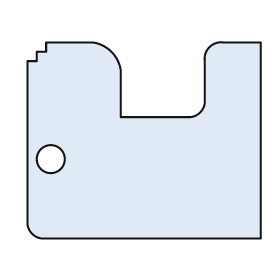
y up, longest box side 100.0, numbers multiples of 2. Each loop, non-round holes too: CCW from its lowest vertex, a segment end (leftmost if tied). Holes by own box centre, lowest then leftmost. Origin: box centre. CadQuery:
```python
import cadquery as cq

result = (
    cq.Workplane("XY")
    .moveTo(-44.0, -42.0)
    .lineTo(50.0, -42.0)
    .lineTo(50.0, 42.0)
    .lineTo(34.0, 42.0)
    .threePointArc((28.0, 40.0), (26.0, 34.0))
    .lineTo(26.0, 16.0)
    .threePointArc((24.0, 12.0), (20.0, 10.0))
    .lineTo(-10.0, 10.0)
    .lineTo(-10.0, 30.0)
    .threePointArc((-14.0, 38.0), (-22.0, 42.0))
    .lineTo(-42.0, 42.0)
    .lineTo(-42.0, 38.0)
    .lineTo(-46.0, 38.0)
    .lineTo(-46.0, 34.0)
    .lineTo(-50.0, 34.0)
    .lineTo(-50.0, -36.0)
    .threePointArc((-48.0, -40.0), (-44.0, -42.0))
    .close()
    .moveTo(-40.0, -8.0)
    .circle(6.0)
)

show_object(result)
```